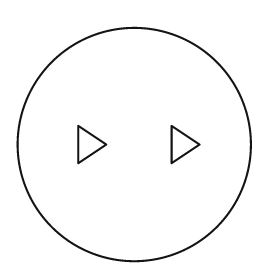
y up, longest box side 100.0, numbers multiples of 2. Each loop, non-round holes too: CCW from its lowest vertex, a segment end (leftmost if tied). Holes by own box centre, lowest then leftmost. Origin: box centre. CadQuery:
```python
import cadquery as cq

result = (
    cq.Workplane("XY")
    .moveTo(0.0, 0.0)
    .circle(50.0)
    .moveTo(-24.0, -8.0)
    .lineTo(-12.0, 0.0)
    .lineTo(-24.0, 8.0)
    .close()
    .moveTo(16.0, -8.0)
    .lineTo(28.0, 0.0)
    .lineTo(16.0, 8.0)
    .close()
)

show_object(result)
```